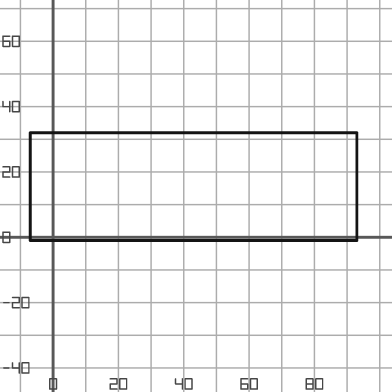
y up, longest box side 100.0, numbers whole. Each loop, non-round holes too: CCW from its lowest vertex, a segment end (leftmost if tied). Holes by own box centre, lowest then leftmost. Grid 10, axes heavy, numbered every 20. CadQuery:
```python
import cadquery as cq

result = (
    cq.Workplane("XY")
    .moveTo(-7.0, -1.0)
    .lineTo(93.0, -1.0)
    .lineTo(93.0, 32.0)
    .lineTo(-7.0, 32.0)
    .close()
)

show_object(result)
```